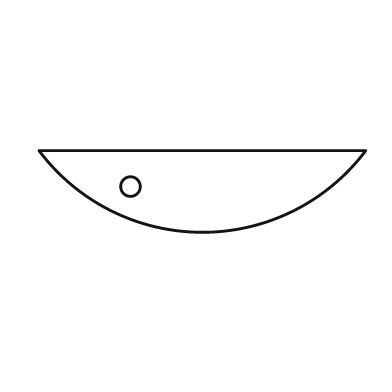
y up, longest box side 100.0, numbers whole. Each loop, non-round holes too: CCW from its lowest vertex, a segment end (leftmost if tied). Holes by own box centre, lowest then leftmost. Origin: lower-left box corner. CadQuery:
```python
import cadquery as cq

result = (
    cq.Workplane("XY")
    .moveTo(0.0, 25.0)
    .threePointArc((50.0, 0.0), (100.0, 25.0))
    .close()
    .moveTo(28.0, 14.0)
    .circle(3.0)
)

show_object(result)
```